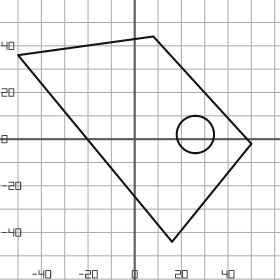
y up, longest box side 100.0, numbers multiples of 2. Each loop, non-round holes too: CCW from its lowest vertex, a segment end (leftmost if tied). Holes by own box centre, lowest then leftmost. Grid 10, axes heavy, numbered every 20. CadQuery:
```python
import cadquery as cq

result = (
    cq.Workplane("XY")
    .moveTo(16.0, -44.0)
    .lineTo(50.0, -2.0)
    .lineTo(8.0, 44.0)
    .lineTo(-50.0, 36.0)
    .close()
    .moveTo(26.0, 2.0)
    .circle(8.0)
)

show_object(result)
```